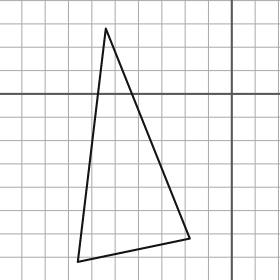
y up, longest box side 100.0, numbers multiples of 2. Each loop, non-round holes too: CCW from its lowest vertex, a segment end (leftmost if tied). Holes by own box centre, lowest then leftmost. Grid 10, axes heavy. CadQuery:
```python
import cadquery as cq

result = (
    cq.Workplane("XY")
    .moveTo(-66.0, -72.0)
    .lineTo(-18.0, -62.0)
    .lineTo(-54.0, 28.0)
    .close()
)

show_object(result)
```